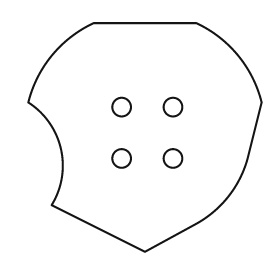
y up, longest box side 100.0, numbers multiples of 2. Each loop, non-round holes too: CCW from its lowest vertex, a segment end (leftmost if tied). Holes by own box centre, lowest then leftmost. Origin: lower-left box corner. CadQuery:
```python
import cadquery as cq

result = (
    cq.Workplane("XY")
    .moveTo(50.0, 0.0)
    .lineTo(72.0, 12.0)
    .threePointArc((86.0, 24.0), (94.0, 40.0))
    .lineTo(100.0, 64.0)
    .threePointArc((90.0, 84.0), (72.0, 98.0))
    .lineTo(28.0, 98.0)
    .threePointArc((10.0, 84.0), (0.0, 64.0))
    .threePointArc((14.0, 44.0), (10.0, 20.0))
    .close()
    .moveTo(40.0, 40.0)
    .circle(4.0)
    .moveTo(62.0, 40.0)
    .circle(4.0)
    .moveTo(40.0, 62.0)
    .circle(4.0)
    .moveTo(62.0, 62.0)
    .circle(4.0)
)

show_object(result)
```